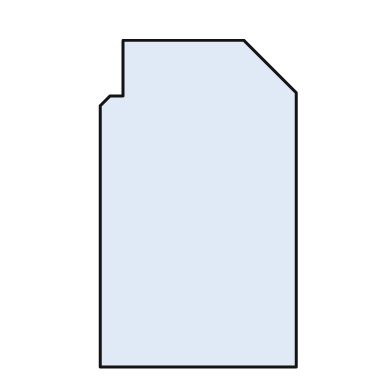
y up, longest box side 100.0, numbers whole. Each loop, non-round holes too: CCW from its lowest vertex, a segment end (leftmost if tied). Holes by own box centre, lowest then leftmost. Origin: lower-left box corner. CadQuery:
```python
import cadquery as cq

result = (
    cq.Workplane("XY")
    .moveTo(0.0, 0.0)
    .lineTo(60.0, 0.0)
    .lineTo(60.0, 84.0)
    .lineTo(44.0, 100.0)
    .lineTo(7.0, 100.0)
    .lineTo(7.0, 83.0)
    .lineTo(3.0, 83.0)
    .lineTo(0.0, 80.0)
    .close()
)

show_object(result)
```